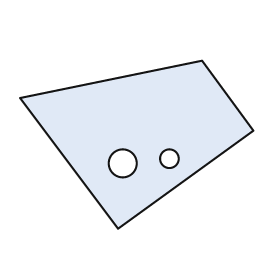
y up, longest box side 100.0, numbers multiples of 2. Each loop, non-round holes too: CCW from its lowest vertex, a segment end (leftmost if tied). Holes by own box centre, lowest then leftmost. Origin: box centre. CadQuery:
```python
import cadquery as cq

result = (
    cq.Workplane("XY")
    .moveTo(-8.0, -36.0)
    .lineTo(50.0, 6.0)
    .lineTo(28.0, 36.0)
    .lineTo(-50.0, 20.0)
    .close()
    .moveTo(-6.0, -8.0)
    .circle(6.0)
    .moveTo(14.0, -6.0)
    .circle(4.0)
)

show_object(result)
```